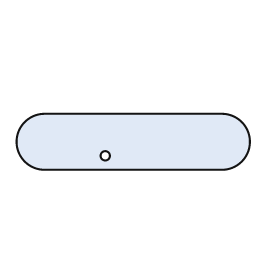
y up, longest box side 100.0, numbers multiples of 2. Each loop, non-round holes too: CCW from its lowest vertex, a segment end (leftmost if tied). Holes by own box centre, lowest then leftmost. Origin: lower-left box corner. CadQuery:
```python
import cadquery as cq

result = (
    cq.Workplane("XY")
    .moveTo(12.0, 0.0)
    .lineTo(88.0, 0.0)
    .threePointArc((100.0, 12.0), (88.0, 24.0))
    .lineTo(12.0, 24.0)
    .threePointArc((0.0, 12.0), (12.0, 0.0))
    .close()
    .moveTo(38.0, 6.0)
    .circle(2.0)
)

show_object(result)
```